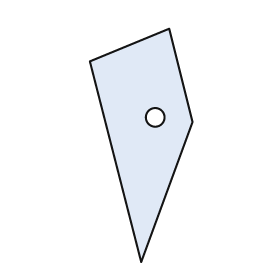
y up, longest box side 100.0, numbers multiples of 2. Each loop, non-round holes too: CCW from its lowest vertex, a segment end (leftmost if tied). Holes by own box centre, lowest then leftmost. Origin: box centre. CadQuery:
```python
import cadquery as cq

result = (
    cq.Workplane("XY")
    .moveTo(0.0, -50.0)
    .lineTo(22.0, 10.0)
    .lineTo(12.0, 50.0)
    .lineTo(-22.0, 36.0)
    .close()
    .moveTo(6.0, 12.0)
    .circle(4.0)
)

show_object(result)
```